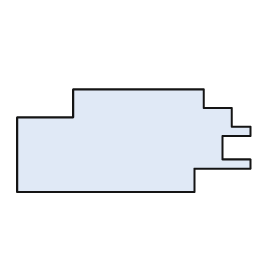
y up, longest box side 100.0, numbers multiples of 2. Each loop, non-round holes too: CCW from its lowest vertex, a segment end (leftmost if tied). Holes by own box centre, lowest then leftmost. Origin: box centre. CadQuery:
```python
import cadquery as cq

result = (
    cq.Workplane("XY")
    .moveTo(-50.0, -22.0)
    .lineTo(26.0, -22.0)
    .lineTo(26.0, -12.0)
    .lineTo(50.0, -12.0)
    .lineTo(50.0, -8.0)
    .lineTo(38.0, -8.0)
    .lineTo(38.0, 2.0)
    .lineTo(50.0, 2.0)
    .lineTo(50.0, 6.0)
    .lineTo(42.0, 6.0)
    .lineTo(42.0, 14.0)
    .lineTo(30.0, 14.0)
    .lineTo(30.0, 22.0)
    .lineTo(-26.0, 22.0)
    .lineTo(-26.0, 10.0)
    .lineTo(-50.0, 10.0)
    .close()
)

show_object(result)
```